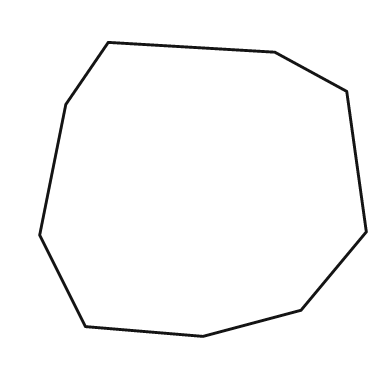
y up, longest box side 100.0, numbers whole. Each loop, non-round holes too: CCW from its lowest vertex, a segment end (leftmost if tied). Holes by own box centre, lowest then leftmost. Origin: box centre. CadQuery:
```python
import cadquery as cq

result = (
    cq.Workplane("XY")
    .moveTo(0.0, -45.0)
    .lineTo(30.0, -37.0)
    .lineTo(50.0, -13.0)
    .lineTo(44.0, 30.0)
    .lineTo(22.0, 42.0)
    .lineTo(-29.0, 45.0)
    .lineTo(-42.0, 26.0)
    .lineTo(-50.0, -14.0)
    .lineTo(-36.0, -42.0)
    .close()
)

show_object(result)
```